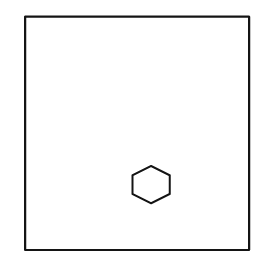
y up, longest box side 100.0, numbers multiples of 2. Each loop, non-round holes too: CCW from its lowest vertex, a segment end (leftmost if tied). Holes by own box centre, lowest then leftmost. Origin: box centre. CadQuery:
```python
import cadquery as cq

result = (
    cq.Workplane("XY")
    .moveTo(-48.0, -50.0)
    .lineTo(48.0, -50.0)
    .lineTo(48.0, 50.0)
    .lineTo(-48.0, 50.0)
    .close()
    .moveTo(6.0, -30.0)
    .lineTo(14.0, -26.0)
    .lineTo(14.0, -18.0)
    .lineTo(6.0, -14.0)
    .lineTo(-2.0, -18.0)
    .lineTo(-2.0, -26.0)
    .close()
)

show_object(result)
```